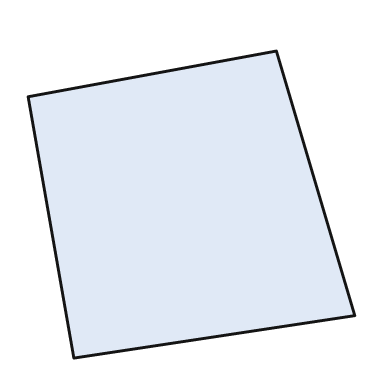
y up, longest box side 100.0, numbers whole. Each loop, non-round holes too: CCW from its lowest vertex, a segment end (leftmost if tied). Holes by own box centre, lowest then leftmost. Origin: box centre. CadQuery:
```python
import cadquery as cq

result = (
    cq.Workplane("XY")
    .moveTo(-36.0, -47.0)
    .lineTo(50.0, -34.0)
    .lineTo(26.0, 47.0)
    .lineTo(-50.0, 33.0)
    .close()
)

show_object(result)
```